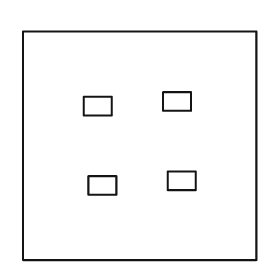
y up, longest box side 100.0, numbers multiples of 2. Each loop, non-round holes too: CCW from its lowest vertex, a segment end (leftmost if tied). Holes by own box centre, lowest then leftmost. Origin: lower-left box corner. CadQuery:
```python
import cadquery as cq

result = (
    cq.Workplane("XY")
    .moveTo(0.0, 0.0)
    .lineTo(100.0, 0.0)
    .lineTo(100.0, 98.0)
    .lineTo(0.0, 98.0)
    .close()
    .moveTo(28.0, 28.0)
    .lineTo(40.0, 28.0)
    .lineTo(40.0, 36.0)
    .lineTo(28.0, 36.0)
    .close()
    .moveTo(62.0, 30.0)
    .lineTo(74.0, 30.0)
    .lineTo(74.0, 38.0)
    .lineTo(62.0, 38.0)
    .close()
    .moveTo(26.0, 62.0)
    .lineTo(38.0, 62.0)
    .lineTo(38.0, 70.0)
    .lineTo(26.0, 70.0)
    .close()
    .moveTo(60.0, 64.0)
    .lineTo(72.0, 64.0)
    .lineTo(72.0, 72.0)
    .lineTo(60.0, 72.0)
    .close()
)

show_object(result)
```